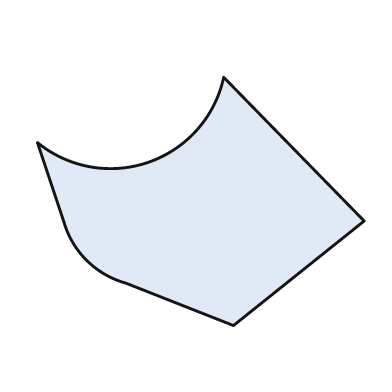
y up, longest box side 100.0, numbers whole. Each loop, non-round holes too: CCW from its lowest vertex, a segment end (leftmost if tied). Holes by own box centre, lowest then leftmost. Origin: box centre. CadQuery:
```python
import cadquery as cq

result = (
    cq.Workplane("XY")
    .moveTo(10.0, -38.0)
    .lineTo(50.0, -6.0)
    .lineTo(7.0, 38.0)
    .threePointArc((-16.0, 12.0), (-50.0, 18.0))
    .lineTo(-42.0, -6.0)
    .threePointArc((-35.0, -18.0), (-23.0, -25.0))
    .close()
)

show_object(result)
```